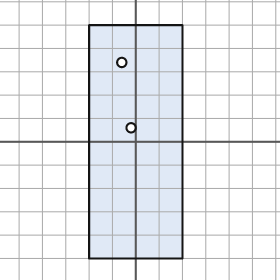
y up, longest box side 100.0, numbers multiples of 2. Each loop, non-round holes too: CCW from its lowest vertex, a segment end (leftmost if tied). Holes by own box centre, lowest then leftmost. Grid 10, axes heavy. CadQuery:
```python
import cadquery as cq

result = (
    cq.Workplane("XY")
    .moveTo(-20.0, -50.0)
    .lineTo(20.0, -50.0)
    .lineTo(20.0, 50.0)
    .lineTo(-20.0, 50.0)
    .close()
    .moveTo(-2.0, 6.0)
    .circle(2.0)
    .moveTo(-6.0, 34.0)
    .circle(2.0)
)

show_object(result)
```